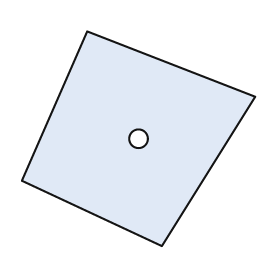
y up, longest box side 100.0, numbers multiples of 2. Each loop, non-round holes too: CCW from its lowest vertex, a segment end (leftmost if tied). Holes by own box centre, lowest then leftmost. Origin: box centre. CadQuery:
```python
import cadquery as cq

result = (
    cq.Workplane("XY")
    .moveTo(10.0, -46.0)
    .lineTo(50.0, 18.0)
    .lineTo(-22.0, 46.0)
    .lineTo(-50.0, -18.0)
    .close()
    .moveTo(0.0, 0.0)
    .circle(4.0)
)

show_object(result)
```